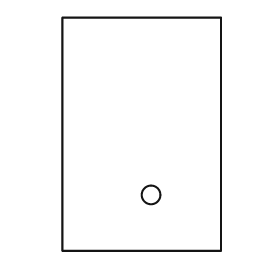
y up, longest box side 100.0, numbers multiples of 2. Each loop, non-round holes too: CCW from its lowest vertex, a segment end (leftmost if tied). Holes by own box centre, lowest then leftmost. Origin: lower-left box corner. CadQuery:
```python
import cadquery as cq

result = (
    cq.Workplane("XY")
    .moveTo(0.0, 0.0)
    .lineTo(68.0, 0.0)
    .lineTo(68.0, 100.0)
    .lineTo(0.0, 100.0)
    .close()
    .moveTo(38.0, 24.0)
    .circle(4.0)
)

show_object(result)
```